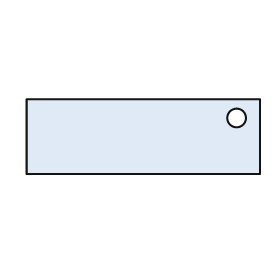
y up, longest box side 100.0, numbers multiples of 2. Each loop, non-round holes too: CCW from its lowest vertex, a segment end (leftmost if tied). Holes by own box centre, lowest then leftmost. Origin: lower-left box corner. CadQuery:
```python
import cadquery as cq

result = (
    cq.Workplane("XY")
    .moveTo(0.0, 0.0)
    .lineTo(100.0, 0.0)
    .lineTo(100.0, 32.0)
    .lineTo(0.0, 32.0)
    .close()
    .moveTo(90.0, 24.0)
    .circle(4.0)
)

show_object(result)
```